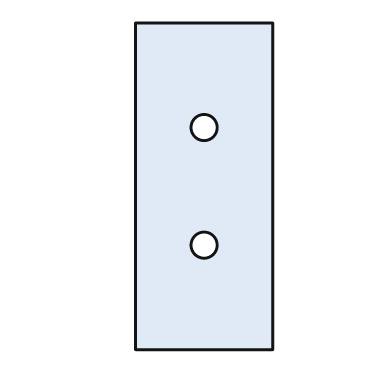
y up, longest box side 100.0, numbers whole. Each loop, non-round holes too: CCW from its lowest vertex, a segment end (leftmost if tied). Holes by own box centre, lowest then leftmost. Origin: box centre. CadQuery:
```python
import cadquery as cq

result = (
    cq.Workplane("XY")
    .moveTo(-21.0, -50.0)
    .lineTo(21.0, -50.0)
    .lineTo(21.0, 50.0)
    .lineTo(-21.0, 50.0)
    .close()
    .moveTo(0.0, -18.0)
    .circle(4.0)
    .moveTo(0.0, 18.0)
    .circle(4.0)
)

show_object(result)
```